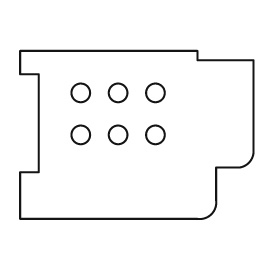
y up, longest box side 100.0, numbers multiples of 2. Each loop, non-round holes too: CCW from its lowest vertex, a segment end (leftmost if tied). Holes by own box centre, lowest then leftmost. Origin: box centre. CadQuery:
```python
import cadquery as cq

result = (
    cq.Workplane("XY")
    .moveTo(-50.0, -36.0)
    .lineTo(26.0, -36.0)
    .threePointArc((32.0, -34.0), (34.0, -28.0))
    .lineTo(34.0, -14.0)
    .lineTo(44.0, -14.0)
    .threePointArc((48.0, -12.0), (50.0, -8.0))
    .lineTo(50.0, 32.0)
    .lineTo(26.0, 32.0)
    .lineTo(26.0, 36.0)
    .lineTo(-50.0, 36.0)
    .lineTo(-50.0, 26.0)
    .lineTo(-42.0, 26.0)
    .lineTo(-42.0, -16.0)
    .lineTo(-50.0, -16.0)
    .close()
    .moveTo(-24.0, 0.0)
    .circle(4.0)
    .moveTo(-8.0, 0.0)
    .circle(4.0)
    .moveTo(8.0, 0.0)
    .circle(4.0)
    .moveTo(-24.0, 18.0)
    .circle(4.0)
    .moveTo(-8.0, 18.0)
    .circle(4.0)
    .moveTo(8.0, 18.0)
    .circle(4.0)
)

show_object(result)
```